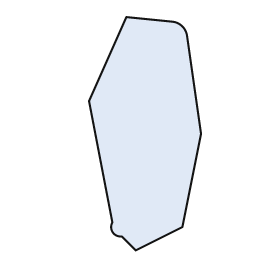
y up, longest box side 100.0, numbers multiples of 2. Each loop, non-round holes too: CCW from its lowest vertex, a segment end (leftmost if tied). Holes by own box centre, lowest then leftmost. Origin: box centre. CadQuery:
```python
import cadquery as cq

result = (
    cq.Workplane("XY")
    .moveTo(-4.0, -50.0)
    .lineTo(16.0, -40.0)
    .lineTo(24.0, 0.0)
    .lineTo(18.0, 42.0)
    .threePointArc((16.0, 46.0), (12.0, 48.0))
    .lineTo(-8.0, 50.0)
    .lineTo(-24.0, 14.0)
    .lineTo(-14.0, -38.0)
    .threePointArc((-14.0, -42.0), (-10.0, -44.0))
    .close()
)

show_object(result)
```